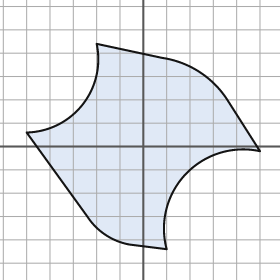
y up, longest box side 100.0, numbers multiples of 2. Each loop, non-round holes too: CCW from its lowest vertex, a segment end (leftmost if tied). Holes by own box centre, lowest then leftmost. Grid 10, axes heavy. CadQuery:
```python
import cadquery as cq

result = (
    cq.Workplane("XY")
    .moveTo(10.0, -44.0)
    .threePointArc((18.0, -12.0), (50.0, -2.0))
    .lineTo(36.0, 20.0)
    .threePointArc((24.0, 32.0), (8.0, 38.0))
    .lineTo(-20.0, 44.0)
    .threePointArc((-26.0, 18.0), (-50.0, 6.0))
    .lineTo(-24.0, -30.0)
    .threePointArc((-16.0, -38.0), (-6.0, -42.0))
    .close()
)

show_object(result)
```